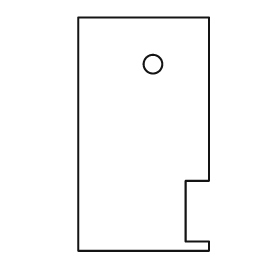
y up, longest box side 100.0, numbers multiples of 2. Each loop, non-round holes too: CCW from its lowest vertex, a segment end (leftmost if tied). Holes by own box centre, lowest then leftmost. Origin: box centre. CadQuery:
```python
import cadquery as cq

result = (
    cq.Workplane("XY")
    .moveTo(-28.0, -50.0)
    .lineTo(28.0, -50.0)
    .lineTo(28.0, -46.0)
    .lineTo(18.0, -46.0)
    .lineTo(18.0, -20.0)
    .lineTo(28.0, -20.0)
    .lineTo(28.0, 50.0)
    .lineTo(-28.0, 50.0)
    .close()
    .moveTo(4.0, 30.0)
    .circle(4.0)
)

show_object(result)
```